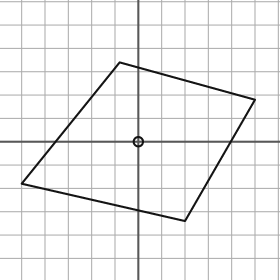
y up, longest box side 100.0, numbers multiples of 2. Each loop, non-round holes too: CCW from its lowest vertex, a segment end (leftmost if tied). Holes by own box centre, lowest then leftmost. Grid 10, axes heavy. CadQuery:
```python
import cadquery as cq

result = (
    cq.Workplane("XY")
    .moveTo(20.0, -34.0)
    .lineTo(50.0, 18.0)
    .lineTo(-8.0, 34.0)
    .lineTo(-50.0, -18.0)
    .close()
    .moveTo(0.0, 0.0)
    .circle(2.0)
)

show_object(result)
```